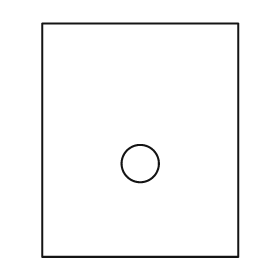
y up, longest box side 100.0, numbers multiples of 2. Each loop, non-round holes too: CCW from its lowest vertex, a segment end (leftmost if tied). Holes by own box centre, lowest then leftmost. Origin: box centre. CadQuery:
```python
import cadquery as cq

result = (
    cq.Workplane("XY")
    .moveTo(-42.0, -50.0)
    .lineTo(42.0, -50.0)
    .lineTo(42.0, 50.0)
    .lineTo(-42.0, 50.0)
    .close()
    .moveTo(0.0, -10.0)
    .circle(8.0)
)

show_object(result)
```